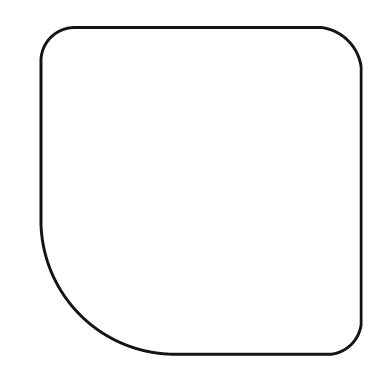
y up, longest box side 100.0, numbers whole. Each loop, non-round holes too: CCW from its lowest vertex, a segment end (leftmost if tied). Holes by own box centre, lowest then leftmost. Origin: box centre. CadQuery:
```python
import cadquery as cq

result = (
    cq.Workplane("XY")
    .moveTo(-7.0, -50.0)
    .lineTo(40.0, -50.0)
    .threePointArc((46.0, -47.0), (49.0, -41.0))
    .lineTo(49.0, 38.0)
    .threePointArc((45.0, 46.0), (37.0, 50.0))
    .lineTo(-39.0, 50.0)
    .threePointArc((-46.0, 47.0), (-49.0, 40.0))
    .lineTo(-49.0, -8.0)
    .threePointArc((-37.0, -38.0), (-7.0, -50.0))
    .close()
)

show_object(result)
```